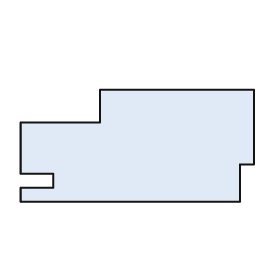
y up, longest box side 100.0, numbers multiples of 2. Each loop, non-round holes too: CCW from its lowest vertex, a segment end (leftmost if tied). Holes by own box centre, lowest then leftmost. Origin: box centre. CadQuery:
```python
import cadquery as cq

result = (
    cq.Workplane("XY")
    .moveTo(-50.0, -24.0)
    .lineTo(44.0, -24.0)
    .lineTo(44.0, -8.0)
    .lineTo(50.0, -8.0)
    .lineTo(50.0, 24.0)
    .lineTo(-16.0, 24.0)
    .lineTo(-16.0, 10.0)
    .lineTo(-50.0, 10.0)
    .lineTo(-50.0, -12.0)
    .lineTo(-36.0, -12.0)
    .lineTo(-36.0, -18.0)
    .lineTo(-50.0, -18.0)
    .close()
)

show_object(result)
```